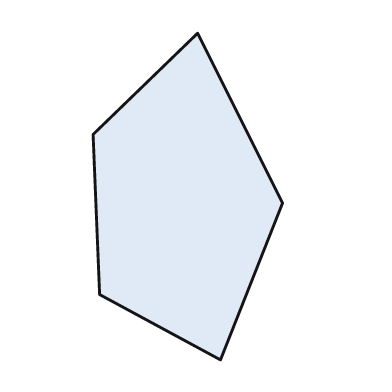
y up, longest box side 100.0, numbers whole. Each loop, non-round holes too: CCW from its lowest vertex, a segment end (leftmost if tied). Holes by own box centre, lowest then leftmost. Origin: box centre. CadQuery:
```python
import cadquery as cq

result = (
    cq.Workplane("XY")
    .moveTo(10.0, -50.0)
    .lineTo(29.0, -2.0)
    .lineTo(3.0, 50.0)
    .lineTo(-29.0, 19.0)
    .lineTo(-27.0, -30.0)
    .close()
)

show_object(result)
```